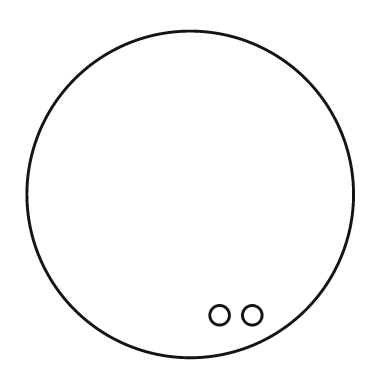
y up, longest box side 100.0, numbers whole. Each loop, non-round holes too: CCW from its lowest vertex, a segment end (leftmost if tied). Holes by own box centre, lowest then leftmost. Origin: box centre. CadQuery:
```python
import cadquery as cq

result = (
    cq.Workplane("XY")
    .moveTo(0.0, 0.0)
    .circle(50.0)
    .moveTo(9.0, -37.0)
    .circle(3.0)
    .moveTo(19.0, -37.0)
    .circle(3.0)
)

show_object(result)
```